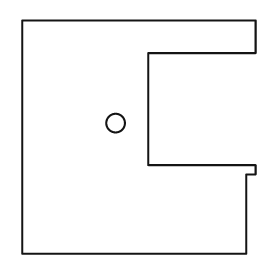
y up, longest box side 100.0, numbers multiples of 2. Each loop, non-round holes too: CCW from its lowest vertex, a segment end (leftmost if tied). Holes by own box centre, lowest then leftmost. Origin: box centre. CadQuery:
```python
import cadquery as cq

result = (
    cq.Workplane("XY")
    .moveTo(-50.0, -50.0)
    .lineTo(46.0, -50.0)
    .lineTo(46.0, -16.0)
    .lineTo(50.0, -16.0)
    .lineTo(50.0, -12.0)
    .lineTo(4.0, -12.0)
    .lineTo(4.0, 36.0)
    .lineTo(50.0, 36.0)
    .lineTo(50.0, 50.0)
    .lineTo(-50.0, 50.0)
    .close()
    .moveTo(-10.0, 6.0)
    .circle(4.0)
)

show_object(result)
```